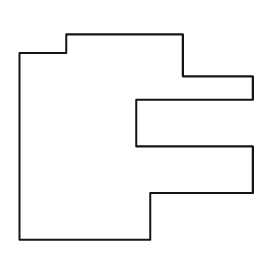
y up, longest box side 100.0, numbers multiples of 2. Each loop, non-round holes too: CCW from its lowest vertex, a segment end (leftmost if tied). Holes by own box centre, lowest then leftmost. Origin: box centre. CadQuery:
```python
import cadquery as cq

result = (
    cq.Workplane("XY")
    .moveTo(-50.0, -44.0)
    .lineTo(6.0, -44.0)
    .lineTo(6.0, -24.0)
    .lineTo(50.0, -24.0)
    .lineTo(50.0, -4.0)
    .lineTo(0.0, -4.0)
    .lineTo(0.0, 16.0)
    .lineTo(50.0, 16.0)
    .lineTo(50.0, 26.0)
    .lineTo(20.0, 26.0)
    .lineTo(20.0, 44.0)
    .lineTo(-30.0, 44.0)
    .lineTo(-30.0, 36.0)
    .lineTo(-50.0, 36.0)
    .close()
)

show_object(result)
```